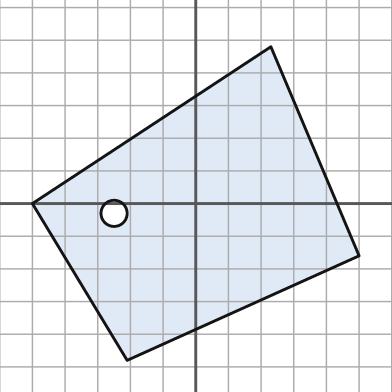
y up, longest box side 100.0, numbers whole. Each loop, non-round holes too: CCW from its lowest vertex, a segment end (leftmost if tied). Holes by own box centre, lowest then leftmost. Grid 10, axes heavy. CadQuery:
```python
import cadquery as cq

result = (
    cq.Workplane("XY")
    .moveTo(-21.0, -48.0)
    .lineTo(50.0, -16.0)
    .lineTo(23.0, 48.0)
    .lineTo(-50.0, 0.0)
    .close()
    .moveTo(-25.0, -3.0)
    .circle(4.0)
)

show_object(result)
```